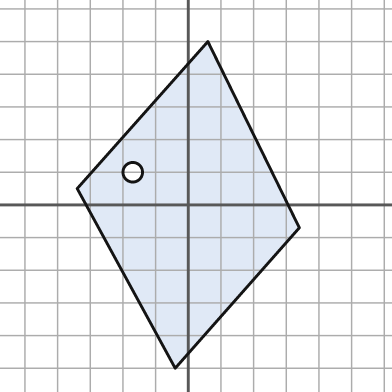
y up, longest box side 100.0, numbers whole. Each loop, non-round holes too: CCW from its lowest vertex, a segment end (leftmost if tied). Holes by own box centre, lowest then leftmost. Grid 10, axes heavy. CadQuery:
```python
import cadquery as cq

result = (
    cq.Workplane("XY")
    .moveTo(-4.0, -50.0)
    .lineTo(34.0, -7.0)
    .lineTo(6.0, 50.0)
    .lineTo(-34.0, 5.0)
    .close()
    .moveTo(-17.0, 10.0)
    .circle(3.0)
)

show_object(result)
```